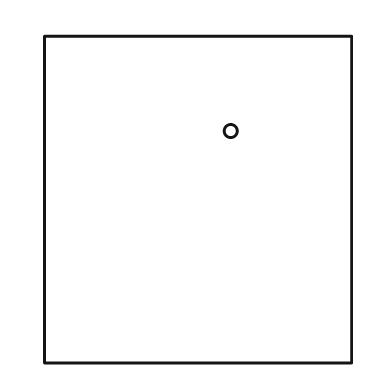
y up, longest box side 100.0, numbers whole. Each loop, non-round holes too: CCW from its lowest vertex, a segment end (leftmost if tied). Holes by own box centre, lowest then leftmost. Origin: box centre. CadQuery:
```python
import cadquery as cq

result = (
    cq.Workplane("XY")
    .moveTo(-47.0, -50.0)
    .lineTo(47.0, -50.0)
    .lineTo(47.0, 50.0)
    .lineTo(-47.0, 50.0)
    .close()
    .moveTo(10.0, 21.0)
    .circle(2.0)
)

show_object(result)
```